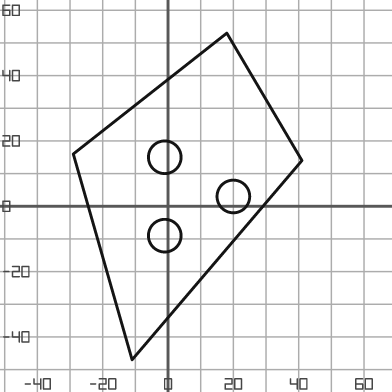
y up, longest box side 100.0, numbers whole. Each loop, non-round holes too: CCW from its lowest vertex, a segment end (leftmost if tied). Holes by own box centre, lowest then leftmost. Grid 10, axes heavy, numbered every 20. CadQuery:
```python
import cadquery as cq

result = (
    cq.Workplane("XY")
    .moveTo(-11.0, -47.0)
    .lineTo(41.0, 14.0)
    .lineTo(18.0, 53.0)
    .lineTo(-29.0, 16.0)
    .close()
    .moveTo(-1.0, -9.0)
    .circle(5.0)
    .moveTo(20.0, 3.0)
    .circle(5.0)
    .moveTo(-1.0, 15.0)
    .circle(5.0)
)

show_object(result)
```